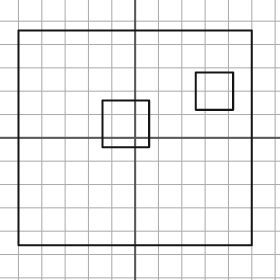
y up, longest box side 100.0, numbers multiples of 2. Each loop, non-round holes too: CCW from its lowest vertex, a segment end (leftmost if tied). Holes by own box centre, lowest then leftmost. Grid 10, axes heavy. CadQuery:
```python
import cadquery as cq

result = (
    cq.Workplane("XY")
    .moveTo(-50.0, -46.0)
    .lineTo(50.0, -46.0)
    .lineTo(50.0, 46.0)
    .lineTo(-50.0, 46.0)
    .close()
    .moveTo(-14.0, -4.0)
    .lineTo(6.0, -4.0)
    .lineTo(6.0, 16.0)
    .lineTo(-14.0, 16.0)
    .close()
    .moveTo(26.0, 12.0)
    .lineTo(42.0, 12.0)
    .lineTo(42.0, 28.0)
    .lineTo(26.0, 28.0)
    .close()
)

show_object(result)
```